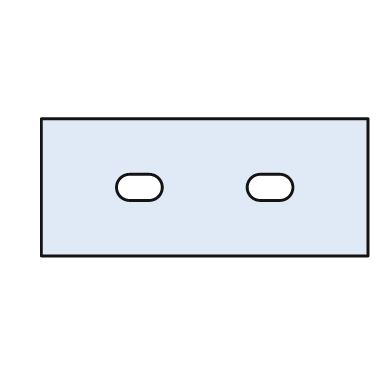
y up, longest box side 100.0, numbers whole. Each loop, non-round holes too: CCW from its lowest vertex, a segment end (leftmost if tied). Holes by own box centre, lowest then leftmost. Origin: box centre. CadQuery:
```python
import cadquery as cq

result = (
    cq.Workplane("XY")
    .moveTo(-50.0, -21.0)
    .lineTo(50.0, -21.0)
    .lineTo(50.0, 21.0)
    .lineTo(-50.0, 21.0)
    .close()
    .moveTo(-23.0, -4.0)
    .lineTo(-17.0, -4.0)
    .threePointArc((-13.0, 0.0), (-17.0, 4.0))
    .lineTo(-23.0, 4.0)
    .threePointArc((-27.0, 0.0), (-23.0, -4.0))
    .close()
    .moveTo(17.0, -4.0)
    .lineTo(23.0, -4.0)
    .threePointArc((27.0, 0.0), (23.0, 4.0))
    .lineTo(17.0, 4.0)
    .threePointArc((13.0, 0.0), (17.0, -4.0))
    .close()
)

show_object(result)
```